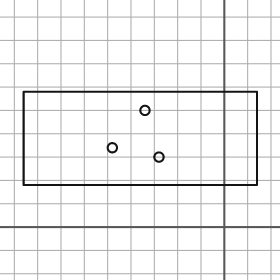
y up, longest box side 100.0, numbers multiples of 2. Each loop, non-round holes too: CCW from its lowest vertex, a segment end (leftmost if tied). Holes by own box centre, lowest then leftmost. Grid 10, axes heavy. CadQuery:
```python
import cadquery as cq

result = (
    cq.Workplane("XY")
    .moveTo(-86.0, 18.0)
    .lineTo(14.0, 18.0)
    .lineTo(14.0, 58.0)
    .lineTo(-86.0, 58.0)
    .close()
    .moveTo(-28.0, 30.0)
    .circle(2.0)
    .moveTo(-48.0, 34.0)
    .circle(2.0)
    .moveTo(-34.0, 50.0)
    .circle(2.0)
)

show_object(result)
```